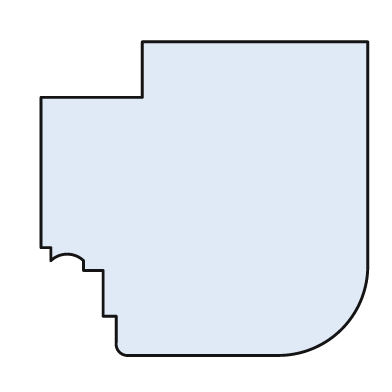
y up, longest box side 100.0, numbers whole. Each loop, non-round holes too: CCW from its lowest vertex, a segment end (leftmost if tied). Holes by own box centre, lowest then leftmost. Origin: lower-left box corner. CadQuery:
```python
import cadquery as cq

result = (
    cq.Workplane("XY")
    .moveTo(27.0, 0.0)
    .lineTo(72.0, 0.0)
    .threePointArc((92.0, 8.0), (100.0, 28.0))
    .lineTo(100.0, 96.0)
    .lineTo(31.0, 96.0)
    .lineTo(31.0, 79.0)
    .lineTo(0.0, 79.0)
    .lineTo(0.0, 33.0)
    .lineTo(3.0, 33.0)
    .lineTo(3.0, 29.0)
    .threePointArc((8.0, 31.0), (13.0, 29.0))
    .lineTo(13.0, 26.0)
    .lineTo(19.0, 26.0)
    .lineTo(19.0, 12.0)
    .lineTo(23.0, 12.0)
    .lineTo(23.0, 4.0)
    .threePointArc((24.0, 1.0), (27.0, 0.0))
    .close()
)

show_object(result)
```